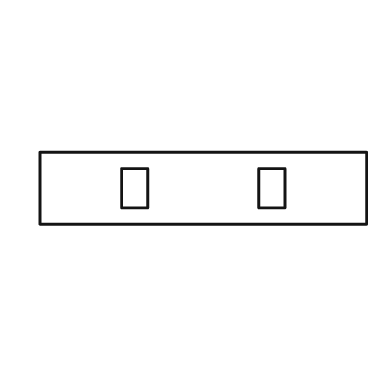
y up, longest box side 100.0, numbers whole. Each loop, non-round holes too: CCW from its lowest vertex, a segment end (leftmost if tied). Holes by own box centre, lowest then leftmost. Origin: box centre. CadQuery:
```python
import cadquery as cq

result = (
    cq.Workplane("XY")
    .moveTo(-50.0, -11.0)
    .lineTo(50.0, -11.0)
    .lineTo(50.0, 11.0)
    .lineTo(-50.0, 11.0)
    .close()
    .moveTo(-25.0, -6.0)
    .lineTo(-17.0, -6.0)
    .lineTo(-17.0, 6.0)
    .lineTo(-25.0, 6.0)
    .close()
    .moveTo(17.0, -6.0)
    .lineTo(25.0, -6.0)
    .lineTo(25.0, 6.0)
    .lineTo(17.0, 6.0)
    .close()
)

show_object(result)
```